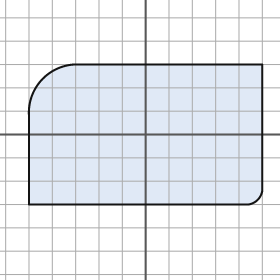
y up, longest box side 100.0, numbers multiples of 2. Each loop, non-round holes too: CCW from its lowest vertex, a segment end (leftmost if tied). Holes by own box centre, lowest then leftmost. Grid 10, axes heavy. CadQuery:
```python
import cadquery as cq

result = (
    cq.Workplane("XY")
    .moveTo(-50.0, -30.0)
    .lineTo(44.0, -30.0)
    .threePointArc((48.0, -28.0), (50.0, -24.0))
    .lineTo(50.0, 30.0)
    .lineTo(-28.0, 30.0)
    .threePointArc((-44.0, 24.0), (-50.0, 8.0))
    .close()
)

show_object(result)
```